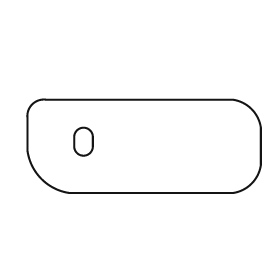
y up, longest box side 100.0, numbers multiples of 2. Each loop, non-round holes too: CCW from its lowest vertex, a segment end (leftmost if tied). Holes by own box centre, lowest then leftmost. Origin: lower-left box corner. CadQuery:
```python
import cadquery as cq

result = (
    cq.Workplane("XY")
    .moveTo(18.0, 0.0)
    .lineTo(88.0, 0.0)
    .threePointArc((96.0, 4.0), (100.0, 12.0))
    .lineTo(100.0, 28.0)
    .threePointArc((96.0, 36.0), (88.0, 40.0))
    .lineTo(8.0, 40.0)
    .threePointArc((2.0, 38.0), (0.0, 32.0))
    .lineTo(0.0, 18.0)
    .threePointArc((6.0, 6.0), (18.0, 0.0))
    .close()
    .moveTo(20.0, 20.0)
    .threePointArc((24.0, 16.0), (28.0, 20.0))
    .lineTo(28.0, 24.0)
    .threePointArc((24.0, 28.0), (20.0, 24.0))
    .close()
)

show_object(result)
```